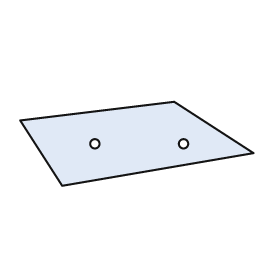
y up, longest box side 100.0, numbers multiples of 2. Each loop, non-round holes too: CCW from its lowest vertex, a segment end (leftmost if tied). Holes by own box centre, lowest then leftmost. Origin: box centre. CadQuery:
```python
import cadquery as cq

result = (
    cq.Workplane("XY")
    .moveTo(-32.0, -18.0)
    .lineTo(50.0, -4.0)
    .lineTo(16.0, 18.0)
    .lineTo(-50.0, 10.0)
    .close()
    .moveTo(-18.0, 0.0)
    .circle(2.0)
    .moveTo(20.0, 0.0)
    .circle(2.0)
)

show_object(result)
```